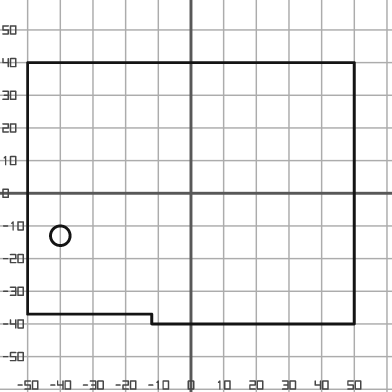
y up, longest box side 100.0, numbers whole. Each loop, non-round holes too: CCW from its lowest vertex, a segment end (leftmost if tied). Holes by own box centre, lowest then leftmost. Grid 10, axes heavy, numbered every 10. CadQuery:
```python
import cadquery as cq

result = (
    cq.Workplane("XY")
    .moveTo(-12.0, -40.0)
    .lineTo(50.0, -40.0)
    .lineTo(50.0, 40.0)
    .lineTo(-50.0, 40.0)
    .lineTo(-50.0, -37.0)
    .lineTo(-12.0, -37.0)
    .close()
    .moveTo(-40.0, -13.0)
    .circle(3.0)
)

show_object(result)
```